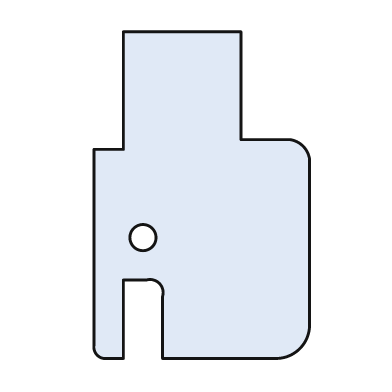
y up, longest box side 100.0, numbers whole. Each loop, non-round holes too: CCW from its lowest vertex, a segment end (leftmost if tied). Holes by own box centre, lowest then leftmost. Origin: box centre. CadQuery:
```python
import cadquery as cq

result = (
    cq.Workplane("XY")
    .moveTo(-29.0, -50.0)
    .lineTo(-24.0, -50.0)
    .lineTo(-24.0, -26.0)
    .lineTo(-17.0, -26.0)
    .threePointArc((-13.0, -27.0), (-12.0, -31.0))
    .lineTo(-12.0, -50.0)
    .lineTo(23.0, -50.0)
    .threePointArc((30.0, -47.0), (33.0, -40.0))
    .lineTo(33.0, 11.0)
    .threePointArc((31.0, 15.0), (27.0, 17.0))
    .lineTo(12.0, 17.0)
    .lineTo(12.0, 50.0)
    .lineTo(-24.0, 50.0)
    .lineTo(-24.0, 14.0)
    .lineTo(-33.0, 14.0)
    .lineTo(-33.0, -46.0)
    .threePointArc((-32.0, -49.0), (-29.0, -50.0))
    .close()
    .moveTo(-18.0, -13.0)
    .circle(4.0)
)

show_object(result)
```